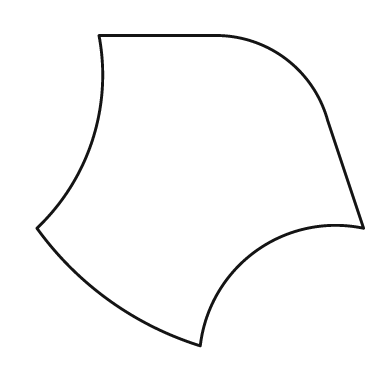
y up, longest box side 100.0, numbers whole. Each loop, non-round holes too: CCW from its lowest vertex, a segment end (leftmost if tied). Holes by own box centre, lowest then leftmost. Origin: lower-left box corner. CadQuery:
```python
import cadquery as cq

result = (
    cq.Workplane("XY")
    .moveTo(50.0, 0.0)
    .threePointArc((67.0, 29.0), (100.0, 36.0))
    .lineTo(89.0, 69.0)
    .threePointArc((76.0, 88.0), (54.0, 95.0))
    .lineTo(19.0, 95.0)
    .threePointArc((17.0, 63.0), (0.0, 36.0))
    .threePointArc((22.0, 14.0), (50.0, 0.0))
    .close()
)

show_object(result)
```